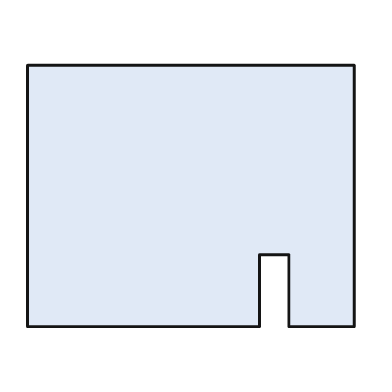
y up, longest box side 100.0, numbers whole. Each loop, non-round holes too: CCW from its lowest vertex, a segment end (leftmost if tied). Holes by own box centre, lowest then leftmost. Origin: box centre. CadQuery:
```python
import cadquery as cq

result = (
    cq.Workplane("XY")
    .moveTo(-50.0, -40.0)
    .lineTo(21.0, -40.0)
    .lineTo(21.0, -18.0)
    .lineTo(30.0, -18.0)
    .lineTo(30.0, -40.0)
    .lineTo(50.0, -40.0)
    .lineTo(50.0, 40.0)
    .lineTo(-50.0, 40.0)
    .close()
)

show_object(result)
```